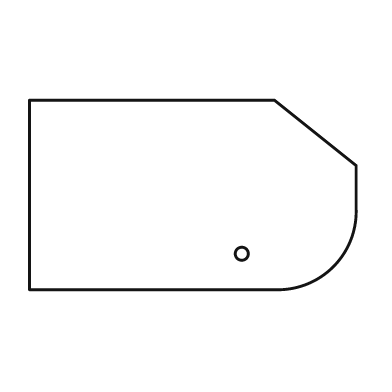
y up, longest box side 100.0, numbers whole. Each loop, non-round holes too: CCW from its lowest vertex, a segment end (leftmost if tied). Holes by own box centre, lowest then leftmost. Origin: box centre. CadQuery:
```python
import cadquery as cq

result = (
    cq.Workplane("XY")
    .moveTo(-50.0, -29.0)
    .lineTo(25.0, -29.0)
    .threePointArc((43.0, -22.0), (50.0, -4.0))
    .lineTo(50.0, 9.0)
    .lineTo(25.0, 29.0)
    .lineTo(-50.0, 29.0)
    .close()
    .moveTo(15.0, -18.0)
    .circle(2.0)
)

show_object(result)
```